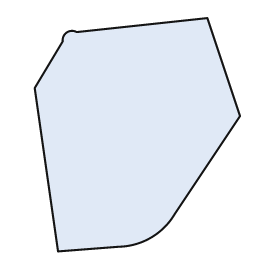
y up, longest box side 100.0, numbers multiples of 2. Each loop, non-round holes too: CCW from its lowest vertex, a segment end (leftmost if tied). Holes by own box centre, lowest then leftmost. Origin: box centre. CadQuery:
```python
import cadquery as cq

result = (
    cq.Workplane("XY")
    .moveTo(-34.0, -50.0)
    .lineTo(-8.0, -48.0)
    .threePointArc((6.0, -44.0), (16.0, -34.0))
    .lineTo(44.0, 8.0)
    .lineTo(30.0, 50.0)
    .lineTo(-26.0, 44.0)
    .threePointArc((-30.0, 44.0), (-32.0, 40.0))
    .lineTo(-44.0, 20.0)
    .close()
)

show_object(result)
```